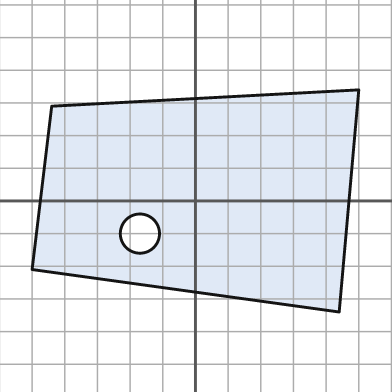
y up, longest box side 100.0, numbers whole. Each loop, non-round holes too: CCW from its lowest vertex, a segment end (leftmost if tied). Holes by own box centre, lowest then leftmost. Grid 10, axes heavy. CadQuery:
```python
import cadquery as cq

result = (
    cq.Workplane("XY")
    .moveTo(44.0, -34.0)
    .lineTo(50.0, 34.0)
    .lineTo(-44.0, 29.0)
    .lineTo(-50.0, -21.0)
    .close()
    .moveTo(-17.0, -10.0)
    .circle(6.0)
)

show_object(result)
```